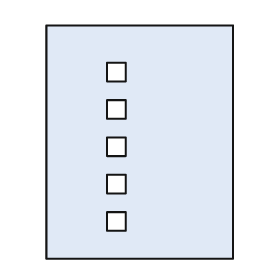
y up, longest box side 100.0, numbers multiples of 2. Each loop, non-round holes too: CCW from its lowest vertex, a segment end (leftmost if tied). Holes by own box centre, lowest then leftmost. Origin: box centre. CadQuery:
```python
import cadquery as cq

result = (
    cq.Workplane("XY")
    .moveTo(-40.0, -50.0)
    .lineTo(40.0, -50.0)
    .lineTo(40.0, 50.0)
    .lineTo(-40.0, 50.0)
    .close()
    .moveTo(-14.0, -38.0)
    .lineTo(-6.0, -38.0)
    .lineTo(-6.0, -30.0)
    .lineTo(-14.0, -30.0)
    .close()
    .moveTo(-14.0, -22.0)
    .lineTo(-6.0, -22.0)
    .lineTo(-6.0, -14.0)
    .lineTo(-14.0, -14.0)
    .close()
    .moveTo(-14.0, -6.0)
    .lineTo(-6.0, -6.0)
    .lineTo(-6.0, 2.0)
    .lineTo(-14.0, 2.0)
    .close()
    .moveTo(-14.0, 10.0)
    .lineTo(-6.0, 10.0)
    .lineTo(-6.0, 18.0)
    .lineTo(-14.0, 18.0)
    .close()
    .moveTo(-14.0, 26.0)
    .lineTo(-6.0, 26.0)
    .lineTo(-6.0, 34.0)
    .lineTo(-14.0, 34.0)
    .close()
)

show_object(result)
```